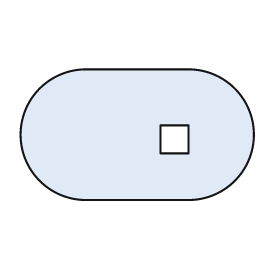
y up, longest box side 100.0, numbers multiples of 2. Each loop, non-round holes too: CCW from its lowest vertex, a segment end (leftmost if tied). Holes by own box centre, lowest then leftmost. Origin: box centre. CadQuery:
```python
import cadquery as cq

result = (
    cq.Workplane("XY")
    .moveTo(-22.0, -28.0)
    .lineTo(22.0, -28.0)
    .threePointArc((50.0, 0.0), (22.0, 28.0))
    .lineTo(-22.0, 28.0)
    .threePointArc((-50.0, 0.0), (-22.0, -28.0))
    .close()
    .moveTo(10.0, -8.0)
    .lineTo(22.0, -8.0)
    .lineTo(22.0, 4.0)
    .lineTo(10.0, 4.0)
    .close()
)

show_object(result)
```